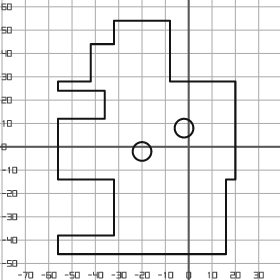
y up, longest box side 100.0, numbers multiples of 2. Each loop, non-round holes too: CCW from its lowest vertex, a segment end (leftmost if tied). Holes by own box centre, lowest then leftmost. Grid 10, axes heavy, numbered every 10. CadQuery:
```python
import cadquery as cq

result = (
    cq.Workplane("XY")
    .moveTo(-56.0, -46.0)
    .lineTo(16.0, -46.0)
    .lineTo(16.0, -14.0)
    .lineTo(20.0, -14.0)
    .lineTo(20.0, 28.0)
    .lineTo(-8.0, 28.0)
    .lineTo(-8.0, 54.0)
    .lineTo(-32.0, 54.0)
    .lineTo(-32.0, 44.0)
    .lineTo(-42.0, 44.0)
    .lineTo(-42.0, 28.0)
    .lineTo(-56.0, 28.0)
    .lineTo(-56.0, 24.0)
    .lineTo(-36.0, 24.0)
    .lineTo(-36.0, 12.0)
    .lineTo(-56.0, 12.0)
    .lineTo(-56.0, -14.0)
    .lineTo(-32.0, -14.0)
    .lineTo(-32.0, -38.0)
    .lineTo(-56.0, -38.0)
    .close()
    .moveTo(-20.0, -2.0)
    .circle(4.0)
    .moveTo(-2.0, 8.0)
    .circle(4.0)
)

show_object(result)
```